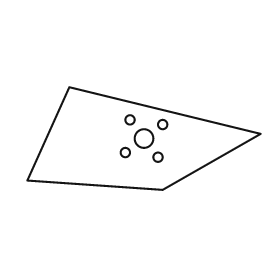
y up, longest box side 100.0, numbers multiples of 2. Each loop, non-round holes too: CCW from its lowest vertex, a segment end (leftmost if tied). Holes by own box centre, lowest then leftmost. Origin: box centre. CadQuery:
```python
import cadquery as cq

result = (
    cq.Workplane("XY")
    .moveTo(8.0, -22.0)
    .lineTo(50.0, 2.0)
    .lineTo(-32.0, 22.0)
    .lineTo(-50.0, -18.0)
    .close()
    .moveTo(6.0, -8.0)
    .circle(2.0)
    .moveTo(-8.0, -6.0)
    .circle(2.0)
    .moveTo(0.0, 0.0)
    .circle(4.0)
    .moveTo(8.0, 6.0)
    .circle(2.0)
    .moveTo(-6.0, 8.0)
    .circle(2.0)
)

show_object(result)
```